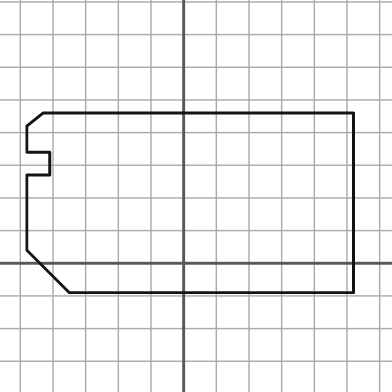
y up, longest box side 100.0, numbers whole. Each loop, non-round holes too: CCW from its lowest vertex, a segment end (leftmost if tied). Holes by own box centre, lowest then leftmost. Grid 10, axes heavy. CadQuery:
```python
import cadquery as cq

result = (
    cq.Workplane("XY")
    .moveTo(-35.0, -9.0)
    .lineTo(52.0, -9.0)
    .lineTo(52.0, 46.0)
    .lineTo(-43.0, 46.0)
    .lineTo(-48.0, 42.0)
    .lineTo(-48.0, 34.0)
    .lineTo(-41.0, 34.0)
    .lineTo(-41.0, 27.0)
    .lineTo(-48.0, 27.0)
    .lineTo(-48.0, 4.0)
    .close()
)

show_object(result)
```